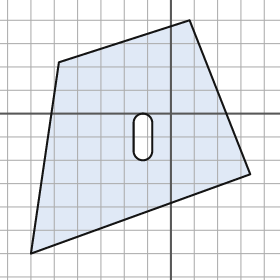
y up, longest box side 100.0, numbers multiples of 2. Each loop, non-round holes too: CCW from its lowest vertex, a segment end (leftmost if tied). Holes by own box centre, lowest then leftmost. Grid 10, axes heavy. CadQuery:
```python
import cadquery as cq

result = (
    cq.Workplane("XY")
    .moveTo(-60.0, -60.0)
    .lineTo(34.0, -26.0)
    .lineTo(8.0, 40.0)
    .lineTo(-48.0, 22.0)
    .close()
    .moveTo(-16.0, -16.0)
    .threePointArc((-12.0, -20.0), (-8.0, -16.0))
    .lineTo(-8.0, -4.0)
    .threePointArc((-12.0, 0.0), (-16.0, -4.0))
    .close()
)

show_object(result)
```